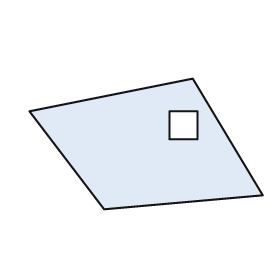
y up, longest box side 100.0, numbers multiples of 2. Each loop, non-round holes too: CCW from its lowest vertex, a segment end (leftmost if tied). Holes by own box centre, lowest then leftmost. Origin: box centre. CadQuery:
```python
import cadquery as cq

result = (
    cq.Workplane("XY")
    .moveTo(-18.0, -28.0)
    .lineTo(50.0, -22.0)
    .lineTo(20.0, 28.0)
    .lineTo(-50.0, 14.0)
    .close()
    .moveTo(10.0, 2.0)
    .lineTo(22.0, 2.0)
    .lineTo(22.0, 14.0)
    .lineTo(10.0, 14.0)
    .close()
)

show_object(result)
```